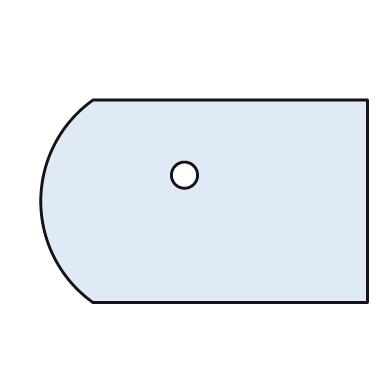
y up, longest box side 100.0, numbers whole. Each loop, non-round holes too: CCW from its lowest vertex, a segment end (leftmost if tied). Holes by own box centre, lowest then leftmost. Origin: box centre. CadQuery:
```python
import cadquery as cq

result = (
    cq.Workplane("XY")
    .moveTo(-34.0, -31.0)
    .lineTo(50.0, -31.0)
    .lineTo(50.0, 31.0)
    .lineTo(-34.0, 31.0)
    .threePointArc((-50.0, 0.0), (-34.0, -31.0))
    .close()
    .moveTo(-6.0, 8.0)
    .circle(4.0)
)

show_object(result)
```